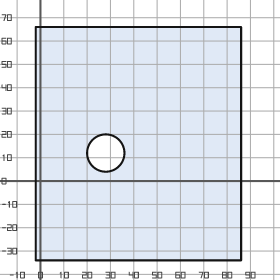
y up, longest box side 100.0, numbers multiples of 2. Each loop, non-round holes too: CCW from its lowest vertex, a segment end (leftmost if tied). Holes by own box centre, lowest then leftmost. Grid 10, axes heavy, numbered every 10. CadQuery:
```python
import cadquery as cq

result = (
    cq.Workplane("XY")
    .moveTo(-2.0, -34.0)
    .lineTo(86.0, -34.0)
    .lineTo(86.0, 66.0)
    .lineTo(-2.0, 66.0)
    .close()
    .moveTo(28.0, 12.0)
    .circle(8.0)
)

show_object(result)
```